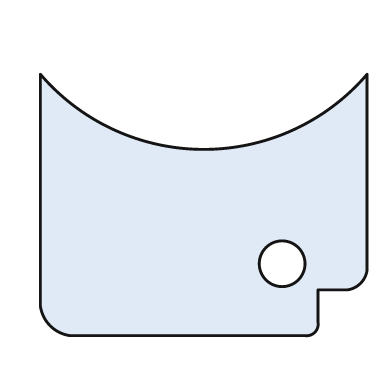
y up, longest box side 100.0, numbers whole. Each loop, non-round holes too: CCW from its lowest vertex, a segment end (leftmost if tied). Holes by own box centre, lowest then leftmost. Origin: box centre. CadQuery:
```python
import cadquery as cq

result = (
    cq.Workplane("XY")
    .moveTo(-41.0, -40.0)
    .lineTo(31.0, -40.0)
    .threePointArc((34.0, -39.0), (35.0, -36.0))
    .lineTo(35.0, -26.0)
    .lineTo(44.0, -26.0)
    .threePointArc((48.0, -24.0), (50.0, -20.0))
    .lineTo(50.0, 40.0)
    .threePointArc((0.0, 17.0), (-50.0, 40.0))
    .lineTo(-50.0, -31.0)
    .threePointArc((-47.0, -37.0), (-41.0, -40.0))
    .close()
    .moveTo(24.0, -18.0)
    .circle(7.0)
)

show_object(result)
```